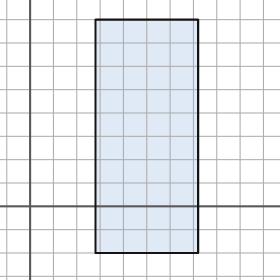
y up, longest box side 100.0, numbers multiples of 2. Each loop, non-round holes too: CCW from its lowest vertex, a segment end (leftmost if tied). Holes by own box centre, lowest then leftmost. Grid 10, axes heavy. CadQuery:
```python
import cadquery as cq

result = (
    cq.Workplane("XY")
    .moveTo(28.0, -20.0)
    .lineTo(72.0, -20.0)
    .lineTo(72.0, 80.0)
    .lineTo(28.0, 80.0)
    .close()
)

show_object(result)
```